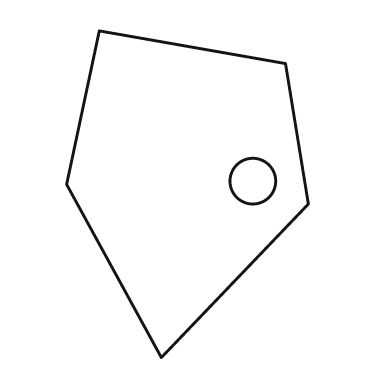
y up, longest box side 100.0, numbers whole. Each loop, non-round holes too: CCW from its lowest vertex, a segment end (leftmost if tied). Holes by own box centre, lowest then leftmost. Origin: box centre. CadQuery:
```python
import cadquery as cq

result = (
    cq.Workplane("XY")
    .moveTo(-8.0, -50.0)
    .lineTo(37.0, -3.0)
    .lineTo(30.0, 40.0)
    .lineTo(-27.0, 50.0)
    .lineTo(-37.0, 3.0)
    .close()
    .moveTo(20.0, 4.0)
    .circle(7.0)
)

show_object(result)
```